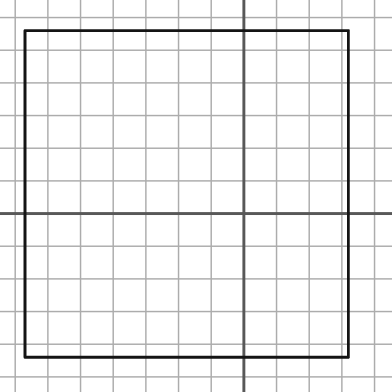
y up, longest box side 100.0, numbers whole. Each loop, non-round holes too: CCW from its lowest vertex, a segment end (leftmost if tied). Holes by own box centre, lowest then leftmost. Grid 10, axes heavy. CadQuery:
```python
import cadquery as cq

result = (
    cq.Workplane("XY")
    .moveTo(-67.0, -44.0)
    .lineTo(32.0, -44.0)
    .lineTo(32.0, 56.0)
    .lineTo(-67.0, 56.0)
    .close()
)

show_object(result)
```